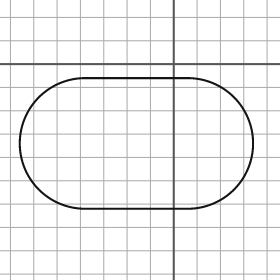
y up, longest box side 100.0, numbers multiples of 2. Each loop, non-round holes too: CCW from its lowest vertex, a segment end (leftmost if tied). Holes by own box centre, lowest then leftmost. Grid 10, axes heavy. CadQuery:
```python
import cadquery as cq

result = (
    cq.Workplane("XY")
    .moveTo(-38.0, -62.0)
    .lineTo(6.0, -62.0)
    .threePointArc((34.0, -34.0), (6.0, -6.0))
    .lineTo(-38.0, -6.0)
    .threePointArc((-66.0, -34.0), (-38.0, -62.0))
    .close()
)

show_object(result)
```